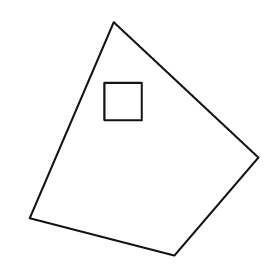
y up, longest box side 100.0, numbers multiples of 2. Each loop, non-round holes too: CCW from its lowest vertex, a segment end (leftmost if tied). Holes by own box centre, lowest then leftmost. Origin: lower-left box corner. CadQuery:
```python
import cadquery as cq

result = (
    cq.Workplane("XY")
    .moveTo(62.0, 0.0)
    .lineTo(98.0, 42.0)
    .lineTo(36.0, 100.0)
    .lineTo(0.0, 16.0)
    .close()
    .moveTo(32.0, 58.0)
    .lineTo(48.0, 58.0)
    .lineTo(48.0, 74.0)
    .lineTo(32.0, 74.0)
    .close()
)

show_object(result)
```